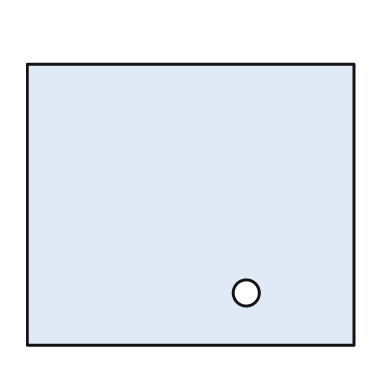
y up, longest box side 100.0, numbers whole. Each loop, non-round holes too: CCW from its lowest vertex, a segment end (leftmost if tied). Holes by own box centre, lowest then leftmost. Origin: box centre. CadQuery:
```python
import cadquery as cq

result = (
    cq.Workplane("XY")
    .moveTo(-50.0, -43.0)
    .lineTo(50.0, -43.0)
    .lineTo(50.0, 43.0)
    .lineTo(-50.0, 43.0)
    .close()
    .moveTo(17.0, -27.0)
    .circle(4.0)
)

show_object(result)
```